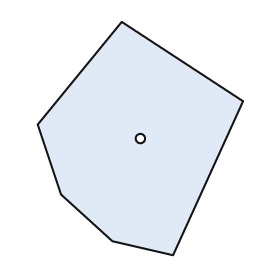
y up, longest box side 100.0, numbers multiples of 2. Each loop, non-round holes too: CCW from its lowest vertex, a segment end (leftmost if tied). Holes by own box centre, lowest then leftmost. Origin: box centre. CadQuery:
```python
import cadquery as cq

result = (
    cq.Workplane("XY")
    .moveTo(14.0, -50.0)
    .lineTo(44.0, 16.0)
    .lineTo(-8.0, 50.0)
    .lineTo(-44.0, 6.0)
    .lineTo(-34.0, -24.0)
    .lineTo(-12.0, -44.0)
    .close()
    .moveTo(0.0, 0.0)
    .circle(2.0)
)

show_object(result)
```